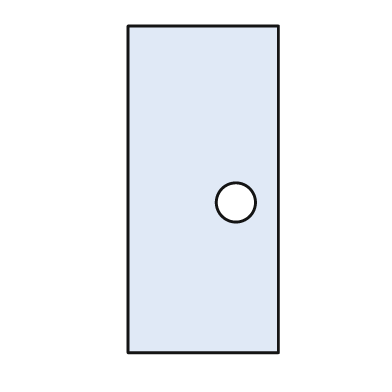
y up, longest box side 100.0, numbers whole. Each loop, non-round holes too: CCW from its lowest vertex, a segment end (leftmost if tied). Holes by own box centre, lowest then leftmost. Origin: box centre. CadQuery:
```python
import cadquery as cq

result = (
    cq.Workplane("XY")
    .moveTo(-23.0, -50.0)
    .lineTo(23.0, -50.0)
    .lineTo(23.0, 50.0)
    .lineTo(-23.0, 50.0)
    .close()
    .moveTo(10.0, -4.0)
    .circle(6.0)
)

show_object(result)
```